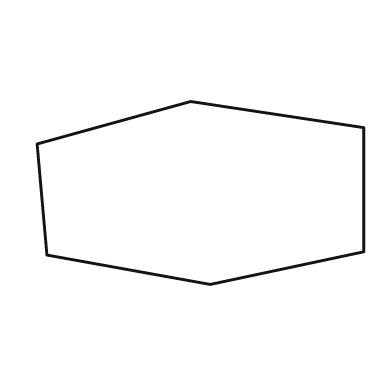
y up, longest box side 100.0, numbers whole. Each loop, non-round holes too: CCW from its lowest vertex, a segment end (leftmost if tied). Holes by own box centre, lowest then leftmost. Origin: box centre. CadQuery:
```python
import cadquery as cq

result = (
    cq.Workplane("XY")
    .moveTo(3.0, -28.0)
    .lineTo(50.0, -18.0)
    .lineTo(50.0, 20.0)
    .lineTo(-3.0, 28.0)
    .lineTo(-50.0, 15.0)
    .lineTo(-47.0, -19.0)
    .close()
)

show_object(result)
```